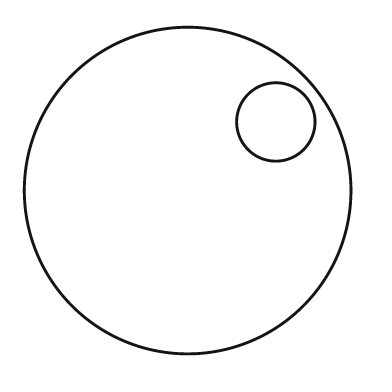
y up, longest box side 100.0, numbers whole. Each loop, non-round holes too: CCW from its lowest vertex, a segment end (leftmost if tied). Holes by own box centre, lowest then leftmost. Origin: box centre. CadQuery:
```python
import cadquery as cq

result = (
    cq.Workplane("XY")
    .moveTo(0.0, 0.0)
    .circle(50.0)
    .moveTo(27.0, 21.0)
    .circle(12.0)
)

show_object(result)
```